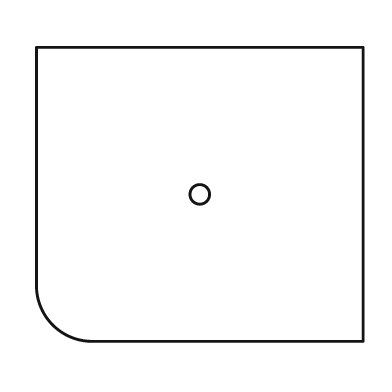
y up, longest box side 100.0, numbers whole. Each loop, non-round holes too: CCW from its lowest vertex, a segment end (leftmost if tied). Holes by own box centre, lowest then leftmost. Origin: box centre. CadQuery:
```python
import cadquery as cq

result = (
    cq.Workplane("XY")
    .moveTo(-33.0, -45.0)
    .lineTo(50.0, -45.0)
    .lineTo(50.0, 45.0)
    .lineTo(-50.0, 45.0)
    .lineTo(-50.0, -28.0)
    .threePointArc((-45.0, -40.0), (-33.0, -45.0))
    .close()
    .moveTo(0.0, 0.0)
    .circle(3.0)
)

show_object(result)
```